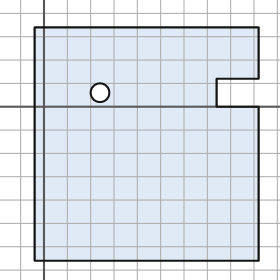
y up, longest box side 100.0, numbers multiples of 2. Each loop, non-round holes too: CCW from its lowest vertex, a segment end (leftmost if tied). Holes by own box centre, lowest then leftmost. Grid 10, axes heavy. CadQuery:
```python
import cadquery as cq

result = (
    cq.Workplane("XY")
    .moveTo(-4.0, -66.0)
    .lineTo(92.0, -66.0)
    .lineTo(92.0, 0.0)
    .lineTo(74.0, 0.0)
    .lineTo(74.0, 12.0)
    .lineTo(92.0, 12.0)
    .lineTo(92.0, 34.0)
    .lineTo(-4.0, 34.0)
    .close()
    .moveTo(24.0, 6.0)
    .circle(4.0)
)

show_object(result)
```